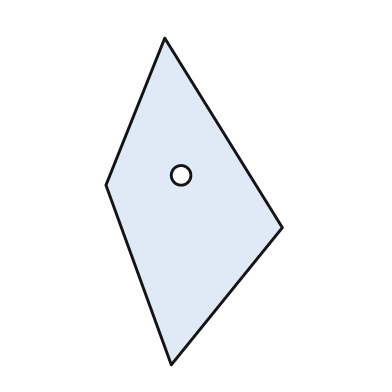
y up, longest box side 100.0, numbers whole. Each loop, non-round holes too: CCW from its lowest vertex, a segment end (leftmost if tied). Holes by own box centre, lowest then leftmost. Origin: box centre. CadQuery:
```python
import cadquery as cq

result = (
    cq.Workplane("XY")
    .moveTo(-7.0, -50.0)
    .lineTo(27.0, -8.0)
    .lineTo(-9.0, 50.0)
    .lineTo(-27.0, 5.0)
    .close()
    .moveTo(-4.0, 8.0)
    .circle(3.0)
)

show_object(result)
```